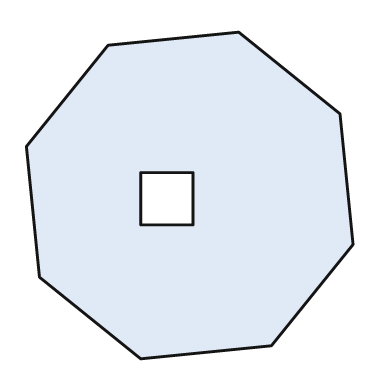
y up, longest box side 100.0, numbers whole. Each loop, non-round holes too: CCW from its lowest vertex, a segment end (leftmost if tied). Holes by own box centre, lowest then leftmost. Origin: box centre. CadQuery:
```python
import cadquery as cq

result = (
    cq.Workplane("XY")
    .moveTo(-15.0, -50.0)
    .lineTo(25.0, -46.0)
    .lineTo(50.0, -15.0)
    .lineTo(46.0, 25.0)
    .lineTo(15.0, 50.0)
    .lineTo(-25.0, 46.0)
    .lineTo(-50.0, 15.0)
    .lineTo(-46.0, -25.0)
    .close()
    .moveTo(-15.0, -9.0)
    .lineTo(1.0, -9.0)
    .lineTo(1.0, 7.0)
    .lineTo(-15.0, 7.0)
    .close()
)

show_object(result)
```